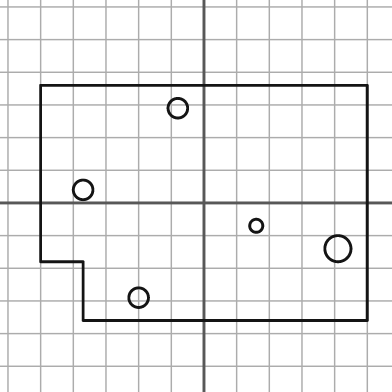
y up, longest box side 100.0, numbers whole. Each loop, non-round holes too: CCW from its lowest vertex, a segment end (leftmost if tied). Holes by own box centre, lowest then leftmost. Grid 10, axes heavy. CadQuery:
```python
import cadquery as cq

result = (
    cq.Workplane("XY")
    .moveTo(-37.0, -36.0)
    .lineTo(50.0, -36.0)
    .lineTo(50.0, 36.0)
    .lineTo(-50.0, 36.0)
    .lineTo(-50.0, -18.0)
    .lineTo(-37.0, -18.0)
    .close()
    .moveTo(-20.0, -29.0)
    .circle(3.0)
    .moveTo(41.0, -14.0)
    .circle(4.0)
    .moveTo(16.0, -7.0)
    .circle(2.0)
    .moveTo(-37.0, 4.0)
    .circle(3.0)
    .moveTo(-8.0, 29.0)
    .circle(3.0)
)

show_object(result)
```